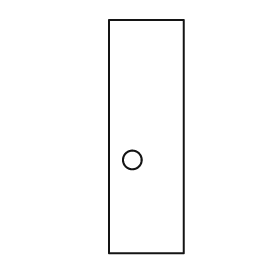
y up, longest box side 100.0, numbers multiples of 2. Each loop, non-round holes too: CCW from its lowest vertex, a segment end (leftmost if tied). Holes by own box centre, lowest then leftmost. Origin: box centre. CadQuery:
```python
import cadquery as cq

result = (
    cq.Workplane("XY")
    .moveTo(-16.0, -50.0)
    .lineTo(16.0, -50.0)
    .lineTo(16.0, 50.0)
    .lineTo(-16.0, 50.0)
    .close()
    .moveTo(-6.0, -10.0)
    .circle(4.0)
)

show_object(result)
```